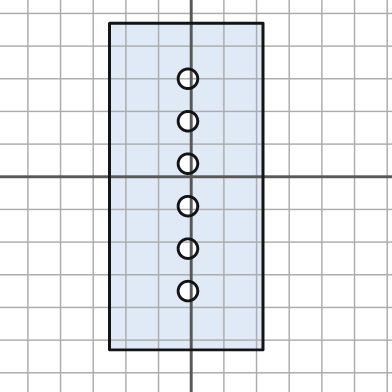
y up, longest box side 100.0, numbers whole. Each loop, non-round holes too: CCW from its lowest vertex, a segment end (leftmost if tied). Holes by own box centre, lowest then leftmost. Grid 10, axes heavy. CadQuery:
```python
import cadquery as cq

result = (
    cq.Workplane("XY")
    .moveTo(-25.0, -53.0)
    .lineTo(22.0, -53.0)
    .lineTo(22.0, 47.0)
    .lineTo(-25.0, 47.0)
    .close()
    .moveTo(-1.0, -35.0)
    .circle(3.0)
    .moveTo(-1.0, -22.0)
    .circle(3.0)
    .moveTo(-1.0, -9.0)
    .circle(3.0)
    .moveTo(-1.0, 4.0)
    .circle(3.0)
    .moveTo(-1.0, 17.0)
    .circle(3.0)
    .moveTo(-1.0, 30.0)
    .circle(3.0)
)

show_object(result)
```